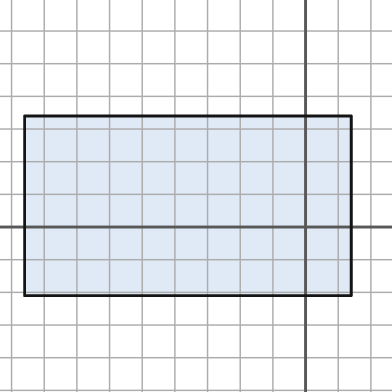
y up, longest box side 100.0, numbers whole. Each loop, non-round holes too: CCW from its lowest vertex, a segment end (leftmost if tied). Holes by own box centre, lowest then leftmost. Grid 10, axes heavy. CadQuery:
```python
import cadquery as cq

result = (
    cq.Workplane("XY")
    .moveTo(-86.0, -21.0)
    .lineTo(14.0, -21.0)
    .lineTo(14.0, 34.0)
    .lineTo(-86.0, 34.0)
    .close()
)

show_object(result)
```